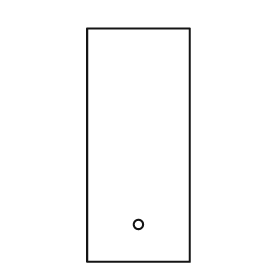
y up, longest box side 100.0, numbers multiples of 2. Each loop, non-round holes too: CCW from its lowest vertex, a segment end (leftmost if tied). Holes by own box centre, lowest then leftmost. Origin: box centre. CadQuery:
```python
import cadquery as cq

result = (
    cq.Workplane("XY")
    .moveTo(-22.0, -50.0)
    .lineTo(22.0, -50.0)
    .lineTo(22.0, 50.0)
    .lineTo(-22.0, 50.0)
    .close()
    .moveTo(0.0, -34.0)
    .circle(2.0)
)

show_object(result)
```